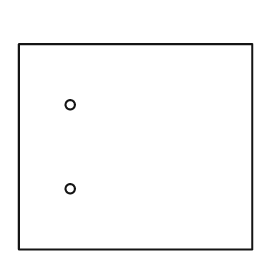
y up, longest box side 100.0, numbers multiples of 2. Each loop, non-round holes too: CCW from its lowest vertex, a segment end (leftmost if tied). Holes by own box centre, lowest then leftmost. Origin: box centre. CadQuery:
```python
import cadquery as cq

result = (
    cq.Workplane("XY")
    .moveTo(-50.0, -44.0)
    .lineTo(50.0, -44.0)
    .lineTo(50.0, 44.0)
    .lineTo(-50.0, 44.0)
    .close()
    .moveTo(-28.0, -18.0)
    .circle(2.0)
    .moveTo(-28.0, 18.0)
    .circle(2.0)
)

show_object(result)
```